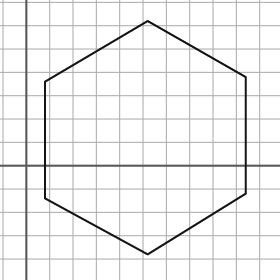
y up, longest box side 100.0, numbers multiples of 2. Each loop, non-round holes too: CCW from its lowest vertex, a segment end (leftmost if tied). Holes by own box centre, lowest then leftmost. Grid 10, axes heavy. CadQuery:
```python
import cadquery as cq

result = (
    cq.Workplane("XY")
    .moveTo(52.0, -38.0)
    .lineTo(94.0, -12.0)
    .lineTo(94.0, 38.0)
    .lineTo(52.0, 62.0)
    .lineTo(8.0, 36.0)
    .lineTo(8.0, -14.0)
    .close()
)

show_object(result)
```